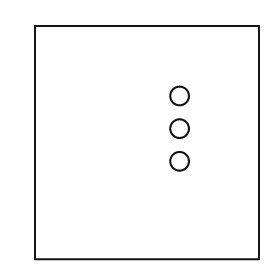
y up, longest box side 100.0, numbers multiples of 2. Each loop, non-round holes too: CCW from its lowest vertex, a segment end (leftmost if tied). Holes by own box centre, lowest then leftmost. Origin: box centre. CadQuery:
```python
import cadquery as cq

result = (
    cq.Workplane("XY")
    .moveTo(-48.0, -50.0)
    .lineTo(48.0, -50.0)
    .lineTo(48.0, 50.0)
    .lineTo(-48.0, 50.0)
    .close()
    .moveTo(14.0, -8.0)
    .circle(4.0)
    .moveTo(14.0, 6.0)
    .circle(4.0)
    .moveTo(14.0, 20.0)
    .circle(4.0)
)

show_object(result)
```